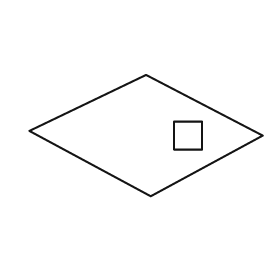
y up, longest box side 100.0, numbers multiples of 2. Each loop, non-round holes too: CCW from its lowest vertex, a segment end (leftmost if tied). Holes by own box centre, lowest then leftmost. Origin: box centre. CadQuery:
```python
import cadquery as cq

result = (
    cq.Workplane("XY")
    .moveTo(2.0, -26.0)
    .lineTo(50.0, 0.0)
    .lineTo(0.0, 26.0)
    .lineTo(-50.0, 2.0)
    .close()
    .moveTo(12.0, -6.0)
    .lineTo(24.0, -6.0)
    .lineTo(24.0, 6.0)
    .lineTo(12.0, 6.0)
    .close()
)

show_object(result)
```